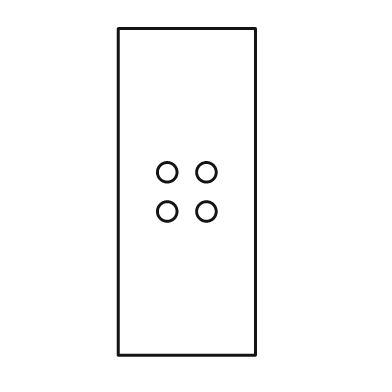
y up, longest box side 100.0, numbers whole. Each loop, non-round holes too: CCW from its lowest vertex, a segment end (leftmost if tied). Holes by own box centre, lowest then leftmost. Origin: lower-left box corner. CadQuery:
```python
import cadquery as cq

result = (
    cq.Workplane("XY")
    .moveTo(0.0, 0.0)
    .lineTo(42.0, 0.0)
    .lineTo(42.0, 100.0)
    .lineTo(0.0, 100.0)
    .close()
    .moveTo(15.0, 44.0)
    .circle(3.0)
    .moveTo(27.0, 44.0)
    .circle(3.0)
    .moveTo(15.0, 56.0)
    .circle(3.0)
    .moveTo(27.0, 56.0)
    .circle(3.0)
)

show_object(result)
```